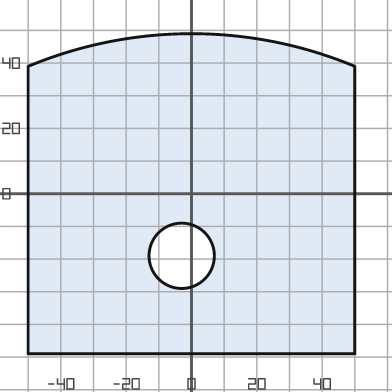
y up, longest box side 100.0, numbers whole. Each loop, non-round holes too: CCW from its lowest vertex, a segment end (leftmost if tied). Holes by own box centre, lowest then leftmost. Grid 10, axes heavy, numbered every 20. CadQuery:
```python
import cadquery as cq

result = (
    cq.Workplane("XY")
    .moveTo(-50.0, -49.0)
    .lineTo(50.0, -49.0)
    .lineTo(50.0, 39.0)
    .threePointArc((0.0, 49.0), (-50.0, 39.0))
    .close()
    .moveTo(-3.0, -19.0)
    .circle(10.0)
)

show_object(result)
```